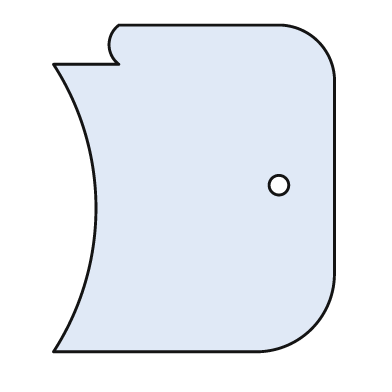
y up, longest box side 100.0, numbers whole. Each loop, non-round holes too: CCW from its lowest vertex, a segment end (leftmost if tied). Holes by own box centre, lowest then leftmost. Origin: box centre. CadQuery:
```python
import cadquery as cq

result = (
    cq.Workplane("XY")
    .moveTo(-43.0, -50.0)
    .lineTo(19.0, -50.0)
    .threePointArc((36.0, -43.0), (43.0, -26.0))
    .lineTo(43.0, 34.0)
    .threePointArc((38.0, 45.0), (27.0, 50.0))
    .lineTo(-23.0, 50.0)
    .threePointArc((-26.0, 44.0), (-23.0, 38.0))
    .lineTo(-43.0, 38.0)
    .threePointArc((-30.0, -6.0), (-43.0, -50.0))
    .close()
    .moveTo(26.0, 1.0)
    .circle(3.0)
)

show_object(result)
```